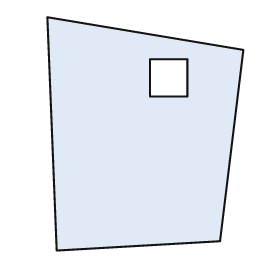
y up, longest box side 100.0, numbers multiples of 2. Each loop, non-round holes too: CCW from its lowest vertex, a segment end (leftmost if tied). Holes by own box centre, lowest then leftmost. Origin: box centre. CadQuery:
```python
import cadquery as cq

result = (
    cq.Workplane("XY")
    .moveTo(-38.0, -50.0)
    .lineTo(32.0, -46.0)
    .lineTo(42.0, 36.0)
    .lineTo(-42.0, 50.0)
    .close()
    .moveTo(2.0, 16.0)
    .lineTo(18.0, 16.0)
    .lineTo(18.0, 32.0)
    .lineTo(2.0, 32.0)
    .close()
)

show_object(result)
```